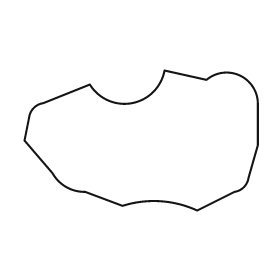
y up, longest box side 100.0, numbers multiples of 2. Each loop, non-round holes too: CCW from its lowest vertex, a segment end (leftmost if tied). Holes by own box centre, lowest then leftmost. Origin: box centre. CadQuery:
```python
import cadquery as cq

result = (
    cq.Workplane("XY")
    .moveTo(24.0, -30.0)
    .lineTo(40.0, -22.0)
    .threePointArc((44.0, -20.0), (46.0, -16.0))
    .lineTo(50.0, -2.0)
    .lineTo(50.0, 16.0)
    .threePointArc((42.0, 28.0), (28.0, 26.0))
    .lineTo(10.0, 30.0)
    .threePointArc((-4.0, 16.0), (-22.0, 24.0))
    .lineTo(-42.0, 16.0)
    .threePointArc((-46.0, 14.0), (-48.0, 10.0))
    .lineTo(-50.0, 0.0)
    .lineTo(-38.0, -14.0)
    .threePointArc((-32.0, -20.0), (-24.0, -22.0))
    .lineTo(-8.0, -28.0)
    .threePointArc((8.0, -26.0), (24.0, -30.0))
    .close()
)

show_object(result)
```